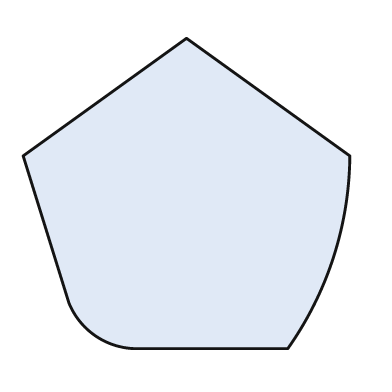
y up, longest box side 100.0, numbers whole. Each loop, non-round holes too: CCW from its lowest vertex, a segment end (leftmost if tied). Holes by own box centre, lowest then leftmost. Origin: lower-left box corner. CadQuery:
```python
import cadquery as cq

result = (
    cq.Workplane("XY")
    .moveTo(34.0, 0.0)
    .lineTo(81.0, 0.0)
    .threePointArc((95.0, 28.0), (100.0, 59.0))
    .lineTo(50.0, 95.0)
    .lineTo(0.0, 59.0)
    .lineTo(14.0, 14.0)
    .threePointArc((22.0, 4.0), (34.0, 0.0))
    .close()
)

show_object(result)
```